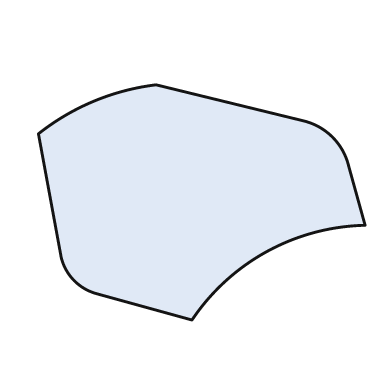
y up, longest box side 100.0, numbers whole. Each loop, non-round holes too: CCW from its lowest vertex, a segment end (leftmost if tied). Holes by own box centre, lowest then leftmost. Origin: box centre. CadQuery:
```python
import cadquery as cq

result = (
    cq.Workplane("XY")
    .moveTo(-3.0, -36.0)
    .threePointArc((20.0, -15.0), (50.0, -7.0))
    .lineTo(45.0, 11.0)
    .threePointArc((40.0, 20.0), (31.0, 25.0))
    .lineTo(-14.0, 36.0)
    .threePointArc((-33.0, 31.0), (-50.0, 21.0))
    .lineTo(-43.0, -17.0)
    .threePointArc((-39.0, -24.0), (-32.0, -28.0))
    .close()
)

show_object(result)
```